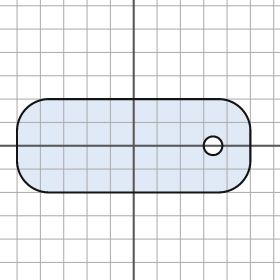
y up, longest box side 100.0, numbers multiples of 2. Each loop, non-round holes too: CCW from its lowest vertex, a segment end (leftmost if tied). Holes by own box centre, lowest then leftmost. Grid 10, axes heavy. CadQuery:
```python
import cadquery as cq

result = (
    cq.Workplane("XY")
    .moveTo(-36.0, -20.0)
    .lineTo(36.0, -20.0)
    .threePointArc((46.0, -16.0), (50.0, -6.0))
    .lineTo(50.0, 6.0)
    .threePointArc((46.0, 16.0), (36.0, 20.0))
    .lineTo(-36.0, 20.0)
    .threePointArc((-46.0, 16.0), (-50.0, 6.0))
    .lineTo(-50.0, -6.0)
    .threePointArc((-46.0, -16.0), (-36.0, -20.0))
    .close()
    .moveTo(34.0, 0.0)
    .circle(4.0)
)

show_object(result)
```